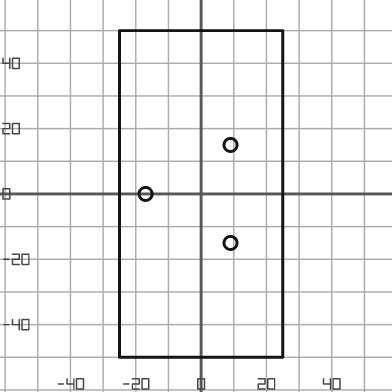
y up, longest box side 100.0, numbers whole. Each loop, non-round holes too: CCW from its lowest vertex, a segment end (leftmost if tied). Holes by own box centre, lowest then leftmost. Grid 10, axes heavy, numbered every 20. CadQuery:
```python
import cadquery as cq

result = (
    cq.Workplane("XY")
    .moveTo(-25.0, -50.0)
    .lineTo(25.0, -50.0)
    .lineTo(25.0, 50.0)
    .lineTo(-25.0, 50.0)
    .close()
    .moveTo(9.0, -15.0)
    .circle(2.0)
    .moveTo(-17.0, 0.0)
    .circle(2.0)
    .moveTo(9.0, 15.0)
    .circle(2.0)
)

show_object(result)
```